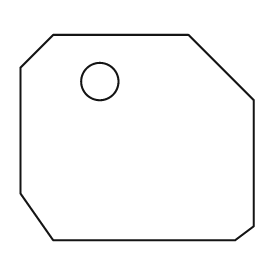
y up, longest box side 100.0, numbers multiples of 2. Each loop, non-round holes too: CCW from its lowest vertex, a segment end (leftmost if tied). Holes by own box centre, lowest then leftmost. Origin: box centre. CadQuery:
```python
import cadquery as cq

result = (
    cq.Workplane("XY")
    .moveTo(-36.0, -44.0)
    .lineTo(42.0, -44.0)
    .lineTo(50.0, -38.0)
    .lineTo(50.0, 16.0)
    .lineTo(22.0, 44.0)
    .lineTo(-36.0, 44.0)
    .lineTo(-50.0, 30.0)
    .lineTo(-50.0, -24.0)
    .close()
    .moveTo(-16.0, 24.0)
    .circle(8.0)
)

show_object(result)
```